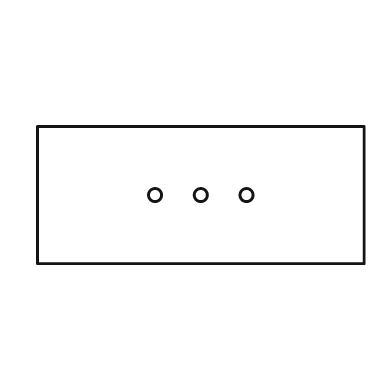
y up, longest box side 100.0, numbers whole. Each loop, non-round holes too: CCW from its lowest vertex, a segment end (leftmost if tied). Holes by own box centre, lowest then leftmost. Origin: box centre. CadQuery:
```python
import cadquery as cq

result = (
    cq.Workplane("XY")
    .moveTo(-50.0, -21.0)
    .lineTo(50.0, -21.0)
    .lineTo(50.0, 21.0)
    .lineTo(-50.0, 21.0)
    .close()
    .moveTo(-14.0, 0.0)
    .circle(2.0)
    .moveTo(0.0, 0.0)
    .circle(2.0)
    .moveTo(14.0, 0.0)
    .circle(2.0)
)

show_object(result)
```